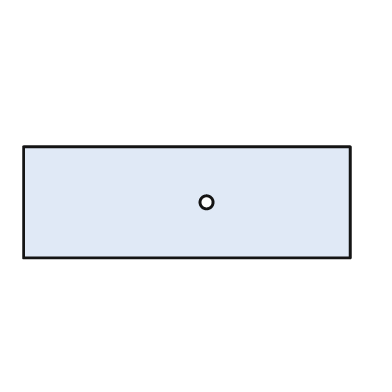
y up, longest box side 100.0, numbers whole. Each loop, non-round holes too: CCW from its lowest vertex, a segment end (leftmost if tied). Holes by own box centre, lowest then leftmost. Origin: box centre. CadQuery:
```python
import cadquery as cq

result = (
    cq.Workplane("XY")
    .moveTo(-50.0, -17.0)
    .lineTo(50.0, -17.0)
    .lineTo(50.0, 17.0)
    .lineTo(-50.0, 17.0)
    .close()
    .moveTo(6.0, 0.0)
    .circle(2.0)
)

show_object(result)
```